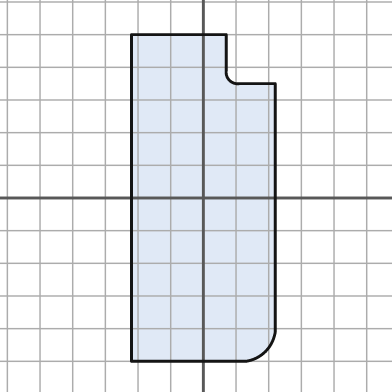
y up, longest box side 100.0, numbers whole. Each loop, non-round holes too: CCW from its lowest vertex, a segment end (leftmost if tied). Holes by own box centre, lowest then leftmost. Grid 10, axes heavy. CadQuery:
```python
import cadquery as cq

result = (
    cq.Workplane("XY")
    .moveTo(-22.0, -50.0)
    .lineTo(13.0, -50.0)
    .threePointArc((19.0, -47.0), (22.0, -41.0))
    .lineTo(22.0, 35.0)
    .lineTo(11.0, 35.0)
    .threePointArc((8.0, 36.0), (7.0, 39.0))
    .lineTo(7.0, 50.0)
    .lineTo(-22.0, 50.0)
    .close()
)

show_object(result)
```